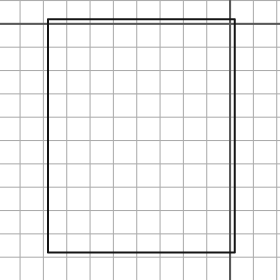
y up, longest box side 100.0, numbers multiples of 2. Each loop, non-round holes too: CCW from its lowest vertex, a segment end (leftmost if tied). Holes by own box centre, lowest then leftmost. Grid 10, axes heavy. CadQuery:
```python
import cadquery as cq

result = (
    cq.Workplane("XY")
    .moveTo(-78.0, -98.0)
    .lineTo(2.0, -98.0)
    .lineTo(2.0, 2.0)
    .lineTo(-78.0, 2.0)
    .close()
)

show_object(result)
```